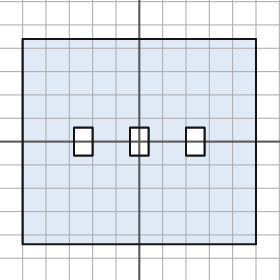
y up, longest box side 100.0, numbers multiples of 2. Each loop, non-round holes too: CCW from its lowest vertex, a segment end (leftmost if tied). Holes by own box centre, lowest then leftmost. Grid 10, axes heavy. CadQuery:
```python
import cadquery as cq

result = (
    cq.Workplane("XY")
    .moveTo(-50.0, -44.0)
    .lineTo(50.0, -44.0)
    .lineTo(50.0, 44.0)
    .lineTo(-50.0, 44.0)
    .close()
    .moveTo(-28.0, -6.0)
    .lineTo(-20.0, -6.0)
    .lineTo(-20.0, 6.0)
    .lineTo(-28.0, 6.0)
    .close()
    .moveTo(-4.0, -6.0)
    .lineTo(4.0, -6.0)
    .lineTo(4.0, 6.0)
    .lineTo(-4.0, 6.0)
    .close()
    .moveTo(20.0, -6.0)
    .lineTo(28.0, -6.0)
    .lineTo(28.0, 6.0)
    .lineTo(20.0, 6.0)
    .close()
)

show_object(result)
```